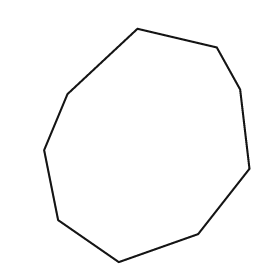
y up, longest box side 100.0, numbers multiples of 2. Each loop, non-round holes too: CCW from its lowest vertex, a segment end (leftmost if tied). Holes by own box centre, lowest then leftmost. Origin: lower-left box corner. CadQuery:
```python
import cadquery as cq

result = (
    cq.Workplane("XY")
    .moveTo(32.0, 0.0)
    .lineTo(66.0, 12.0)
    .lineTo(88.0, 40.0)
    .lineTo(84.0, 74.0)
    .lineTo(74.0, 92.0)
    .lineTo(40.0, 100.0)
    .lineTo(10.0, 72.0)
    .lineTo(0.0, 48.0)
    .lineTo(6.0, 18.0)
    .close()
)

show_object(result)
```